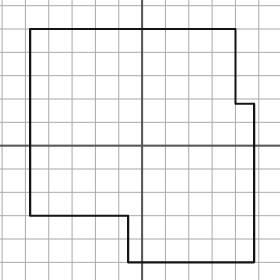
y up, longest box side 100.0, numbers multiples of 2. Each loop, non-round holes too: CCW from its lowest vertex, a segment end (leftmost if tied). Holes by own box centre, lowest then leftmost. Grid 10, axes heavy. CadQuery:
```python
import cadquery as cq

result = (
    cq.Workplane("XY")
    .moveTo(-6.0, -50.0)
    .lineTo(48.0, -50.0)
    .lineTo(48.0, 18.0)
    .lineTo(40.0, 18.0)
    .lineTo(40.0, 50.0)
    .lineTo(-48.0, 50.0)
    .lineTo(-48.0, -30.0)
    .lineTo(-6.0, -30.0)
    .close()
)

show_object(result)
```